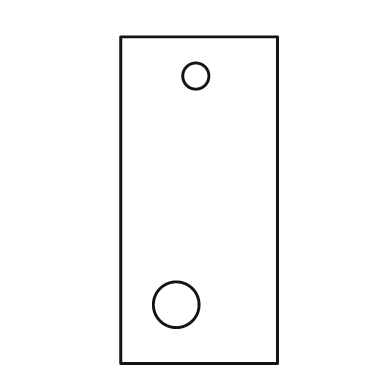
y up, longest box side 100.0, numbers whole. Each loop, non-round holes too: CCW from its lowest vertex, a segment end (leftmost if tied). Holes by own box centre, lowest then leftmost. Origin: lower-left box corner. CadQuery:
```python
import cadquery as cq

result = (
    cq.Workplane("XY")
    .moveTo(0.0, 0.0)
    .lineTo(48.0, 0.0)
    .lineTo(48.0, 100.0)
    .lineTo(0.0, 100.0)
    .close()
    .moveTo(17.0, 18.0)
    .circle(7.0)
    .moveTo(23.0, 88.0)
    .circle(4.0)
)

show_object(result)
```